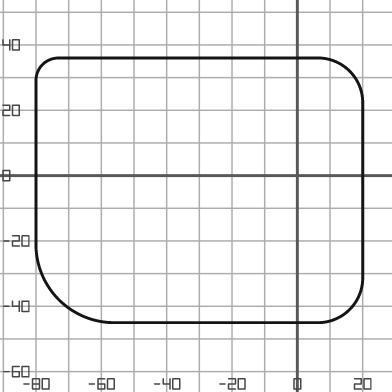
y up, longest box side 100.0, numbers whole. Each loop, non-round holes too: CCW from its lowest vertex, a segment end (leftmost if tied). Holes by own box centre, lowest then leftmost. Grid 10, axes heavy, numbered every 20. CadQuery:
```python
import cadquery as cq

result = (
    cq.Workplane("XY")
    .moveTo(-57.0, -45.0)
    .lineTo(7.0, -45.0)
    .threePointArc((16.0, -41.0), (20.0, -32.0))
    .lineTo(20.0, 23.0)
    .threePointArc((16.0, 32.0), (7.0, 36.0))
    .lineTo(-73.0, 36.0)
    .threePointArc((-78.0, 34.0), (-80.0, 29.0))
    .lineTo(-80.0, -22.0)
    .threePointArc((-73.0, -38.0), (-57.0, -45.0))
    .close()
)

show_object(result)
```